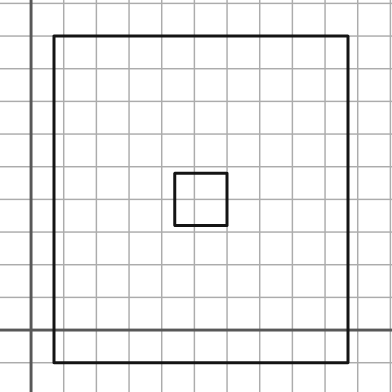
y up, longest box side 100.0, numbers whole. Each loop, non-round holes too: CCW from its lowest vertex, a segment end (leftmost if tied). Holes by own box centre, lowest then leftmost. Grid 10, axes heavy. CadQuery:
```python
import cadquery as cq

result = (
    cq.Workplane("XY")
    .moveTo(7.0, -10.0)
    .lineTo(97.0, -10.0)
    .lineTo(97.0, 90.0)
    .lineTo(7.0, 90.0)
    .close()
    .moveTo(44.0, 32.0)
    .lineTo(60.0, 32.0)
    .lineTo(60.0, 48.0)
    .lineTo(44.0, 48.0)
    .close()
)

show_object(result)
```